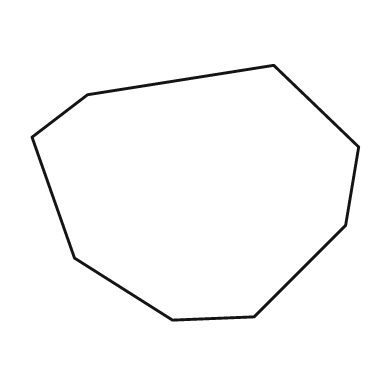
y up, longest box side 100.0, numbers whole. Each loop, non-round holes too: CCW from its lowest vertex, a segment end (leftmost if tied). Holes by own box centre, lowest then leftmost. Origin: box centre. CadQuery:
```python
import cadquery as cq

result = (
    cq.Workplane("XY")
    .moveTo(-7.0, -39.0)
    .lineTo(18.0, -38.0)
    .lineTo(46.0, -10.0)
    .lineTo(50.0, 14.0)
    .lineTo(24.0, 39.0)
    .lineTo(-33.0, 30.0)
    .lineTo(-50.0, 17.0)
    .lineTo(-37.0, -20.0)
    .close()
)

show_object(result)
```